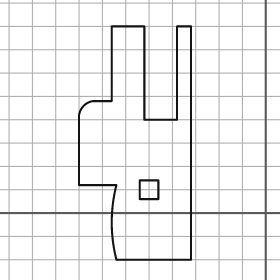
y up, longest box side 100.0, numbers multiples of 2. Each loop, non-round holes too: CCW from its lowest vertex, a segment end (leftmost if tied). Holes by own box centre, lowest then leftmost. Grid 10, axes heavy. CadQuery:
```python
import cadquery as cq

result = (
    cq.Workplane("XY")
    .moveTo(-64.0, -20.0)
    .lineTo(-32.0, -20.0)
    .lineTo(-32.0, 80.0)
    .lineTo(-38.0, 80.0)
    .lineTo(-38.0, 40.0)
    .lineTo(-52.0, 40.0)
    .lineTo(-52.0, 80.0)
    .lineTo(-66.0, 80.0)
    .lineTo(-66.0, 48.0)
    .lineTo(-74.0, 48.0)
    .threePointArc((-78.0, 46.0), (-80.0, 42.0))
    .lineTo(-80.0, 12.0)
    .lineTo(-64.0, 12.0)
    .threePointArc((-66.0, -4.0), (-64.0, -20.0))
    .close()
    .moveTo(-54.0, 6.0)
    .lineTo(-46.0, 6.0)
    .lineTo(-46.0, 14.0)
    .lineTo(-54.0, 14.0)
    .close()
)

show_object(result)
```